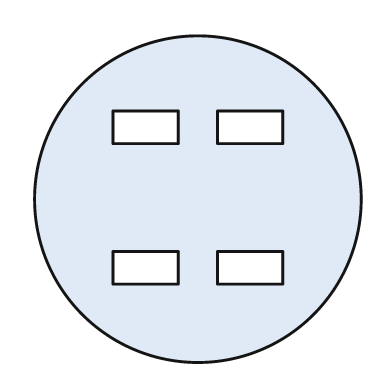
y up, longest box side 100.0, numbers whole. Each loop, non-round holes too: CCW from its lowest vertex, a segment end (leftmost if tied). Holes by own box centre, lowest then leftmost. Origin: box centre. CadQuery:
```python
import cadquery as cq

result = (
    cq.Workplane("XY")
    .moveTo(0.0, 0.0)
    .circle(50.0)
    .moveTo(-26.0, -26.0)
    .lineTo(-6.0, -26.0)
    .lineTo(-6.0, -16.0)
    .lineTo(-26.0, -16.0)
    .close()
    .moveTo(6.0, -26.0)
    .lineTo(26.0, -26.0)
    .lineTo(26.0, -16.0)
    .lineTo(6.0, -16.0)
    .close()
    .moveTo(-26.0, 17.0)
    .lineTo(-6.0, 17.0)
    .lineTo(-6.0, 27.0)
    .lineTo(-26.0, 27.0)
    .close()
    .moveTo(6.0, 17.0)
    .lineTo(26.0, 17.0)
    .lineTo(26.0, 27.0)
    .lineTo(6.0, 27.0)
    .close()
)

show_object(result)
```